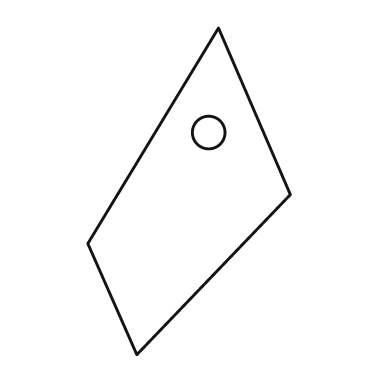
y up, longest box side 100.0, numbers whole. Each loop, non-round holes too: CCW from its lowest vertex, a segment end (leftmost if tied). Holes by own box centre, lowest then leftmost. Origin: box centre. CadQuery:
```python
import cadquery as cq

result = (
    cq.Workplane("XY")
    .moveTo(-16.0, -50.0)
    .lineTo(31.0, -1.0)
    .lineTo(9.0, 50.0)
    .lineTo(-31.0, -16.0)
    .close()
    .moveTo(6.0, 18.0)
    .circle(5.0)
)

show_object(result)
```